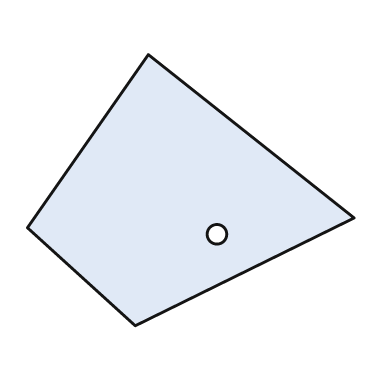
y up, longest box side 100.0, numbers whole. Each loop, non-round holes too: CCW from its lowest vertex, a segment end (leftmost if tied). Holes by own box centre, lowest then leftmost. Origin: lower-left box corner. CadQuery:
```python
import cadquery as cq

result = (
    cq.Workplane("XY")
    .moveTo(33.0, 0.0)
    .lineTo(100.0, 33.0)
    .lineTo(37.0, 83.0)
    .lineTo(0.0, 30.0)
    .close()
    .moveTo(58.0, 28.0)
    .circle(3.0)
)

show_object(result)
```